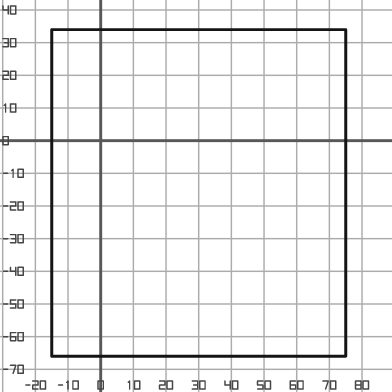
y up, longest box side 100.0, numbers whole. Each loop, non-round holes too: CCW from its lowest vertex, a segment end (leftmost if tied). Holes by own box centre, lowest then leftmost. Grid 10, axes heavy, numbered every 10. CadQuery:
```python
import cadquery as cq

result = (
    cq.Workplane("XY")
    .moveTo(-15.0, -66.0)
    .lineTo(75.0, -66.0)
    .lineTo(75.0, 34.0)
    .lineTo(-15.0, 34.0)
    .close()
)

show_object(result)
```